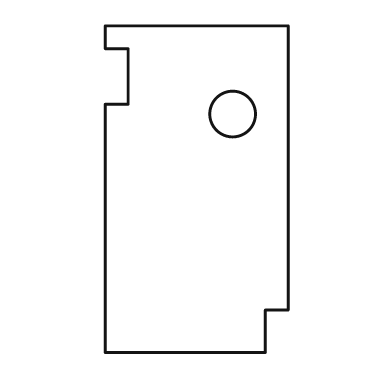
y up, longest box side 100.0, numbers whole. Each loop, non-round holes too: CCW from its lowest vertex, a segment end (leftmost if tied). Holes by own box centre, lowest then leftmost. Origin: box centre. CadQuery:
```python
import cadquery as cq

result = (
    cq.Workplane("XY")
    .moveTo(-28.0, -50.0)
    .lineTo(21.0, -50.0)
    .lineTo(21.0, -37.0)
    .lineTo(28.0, -37.0)
    .lineTo(28.0, 50.0)
    .lineTo(-28.0, 50.0)
    .lineTo(-28.0, 43.0)
    .lineTo(-21.0, 43.0)
    .lineTo(-21.0, 26.0)
    .lineTo(-28.0, 26.0)
    .close()
    .moveTo(11.0, 23.0)
    .circle(7.0)
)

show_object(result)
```